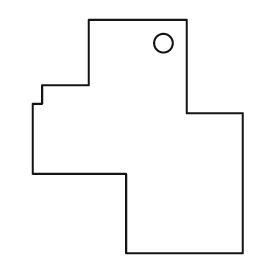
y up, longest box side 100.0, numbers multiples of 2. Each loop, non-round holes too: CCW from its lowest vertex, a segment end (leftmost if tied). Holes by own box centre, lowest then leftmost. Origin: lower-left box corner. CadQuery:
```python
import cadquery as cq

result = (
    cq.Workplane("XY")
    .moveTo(40.0, 0.0)
    .lineTo(90.0, 0.0)
    .lineTo(90.0, 60.0)
    .lineTo(66.0, 60.0)
    .lineTo(66.0, 100.0)
    .lineTo(24.0, 100.0)
    .lineTo(24.0, 72.0)
    .lineTo(4.0, 72.0)
    .lineTo(4.0, 64.0)
    .lineTo(0.0, 64.0)
    .lineTo(0.0, 34.0)
    .lineTo(40.0, 34.0)
    .close()
    .moveTo(56.0, 90.0)
    .circle(4.0)
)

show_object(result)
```